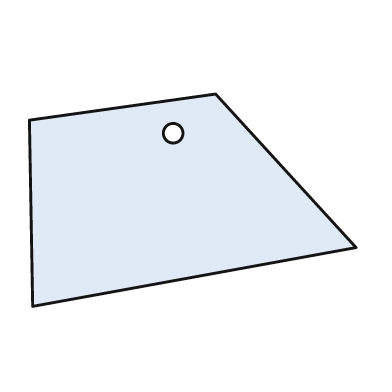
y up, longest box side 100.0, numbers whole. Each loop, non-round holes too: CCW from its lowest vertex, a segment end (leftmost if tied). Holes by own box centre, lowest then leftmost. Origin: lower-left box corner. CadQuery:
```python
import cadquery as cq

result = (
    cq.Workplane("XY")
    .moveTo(1.0, 0.0)
    .lineTo(100.0, 18.0)
    .lineTo(57.0, 65.0)
    .lineTo(0.0, 57.0)
    .close()
    .moveTo(44.0, 53.0)
    .circle(3.0)
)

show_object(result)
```